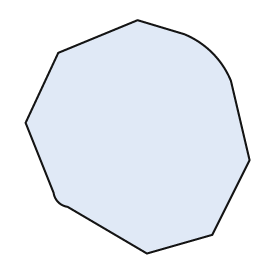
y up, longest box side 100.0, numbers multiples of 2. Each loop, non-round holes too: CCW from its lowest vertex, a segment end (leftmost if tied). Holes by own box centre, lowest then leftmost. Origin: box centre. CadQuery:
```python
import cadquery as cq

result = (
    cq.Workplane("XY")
    .moveTo(4.0, -50.0)
    .lineTo(32.0, -42.0)
    .lineTo(48.0, -10.0)
    .lineTo(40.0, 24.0)
    .threePointArc((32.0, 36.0), (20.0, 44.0))
    .lineTo(0.0, 50.0)
    .lineTo(-34.0, 36.0)
    .lineTo(-48.0, 6.0)
    .lineTo(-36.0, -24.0)
    .threePointArc((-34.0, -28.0), (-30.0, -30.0))
    .close()
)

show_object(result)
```